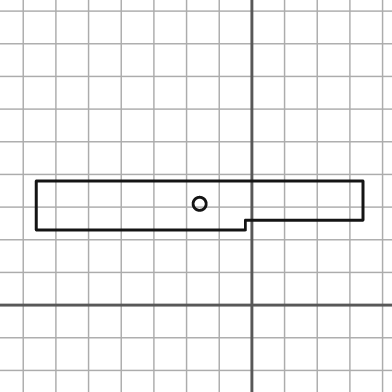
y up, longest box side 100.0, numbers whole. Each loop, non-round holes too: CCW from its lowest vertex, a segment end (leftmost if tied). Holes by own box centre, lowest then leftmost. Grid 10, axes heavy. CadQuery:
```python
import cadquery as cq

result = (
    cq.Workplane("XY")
    .moveTo(-66.0, 23.0)
    .lineTo(-2.0, 23.0)
    .lineTo(-2.0, 26.0)
    .lineTo(34.0, 26.0)
    .lineTo(34.0, 38.0)
    .lineTo(-66.0, 38.0)
    .close()
    .moveTo(-16.0, 31.0)
    .circle(2.0)
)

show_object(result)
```